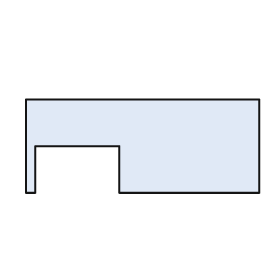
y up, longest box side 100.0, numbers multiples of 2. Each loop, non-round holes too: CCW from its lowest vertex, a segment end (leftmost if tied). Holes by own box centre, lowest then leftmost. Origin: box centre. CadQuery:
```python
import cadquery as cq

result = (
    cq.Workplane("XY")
    .moveTo(-50.0, -20.0)
    .lineTo(-46.0, -20.0)
    .lineTo(-46.0, 0.0)
    .lineTo(-10.0, 0.0)
    .lineTo(-10.0, -20.0)
    .lineTo(50.0, -20.0)
    .lineTo(50.0, 20.0)
    .lineTo(-50.0, 20.0)
    .close()
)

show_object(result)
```